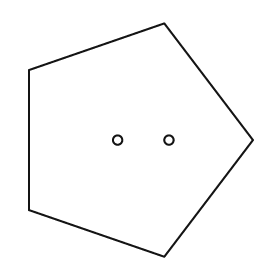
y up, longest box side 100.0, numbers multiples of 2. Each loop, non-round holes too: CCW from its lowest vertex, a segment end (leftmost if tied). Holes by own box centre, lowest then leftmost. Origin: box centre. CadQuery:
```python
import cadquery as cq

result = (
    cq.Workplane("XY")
    .moveTo(10.0, -50.0)
    .lineTo(48.0, 0.0)
    .lineTo(10.0, 50.0)
    .lineTo(-48.0, 30.0)
    .lineTo(-48.0, -30.0)
    .close()
    .moveTo(-10.0, 0.0)
    .circle(2.0)
    .moveTo(12.0, 0.0)
    .circle(2.0)
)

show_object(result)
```